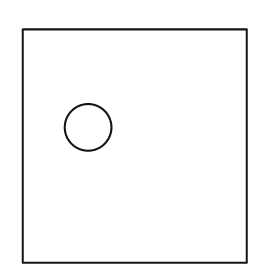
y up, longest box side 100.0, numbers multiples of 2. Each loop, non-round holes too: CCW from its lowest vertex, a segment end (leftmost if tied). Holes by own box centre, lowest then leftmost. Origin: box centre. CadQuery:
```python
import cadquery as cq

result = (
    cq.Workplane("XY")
    .moveTo(-48.0, -50.0)
    .lineTo(48.0, -50.0)
    .lineTo(48.0, 50.0)
    .lineTo(-48.0, 50.0)
    .close()
    .moveTo(-20.0, 8.0)
    .circle(10.0)
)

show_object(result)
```